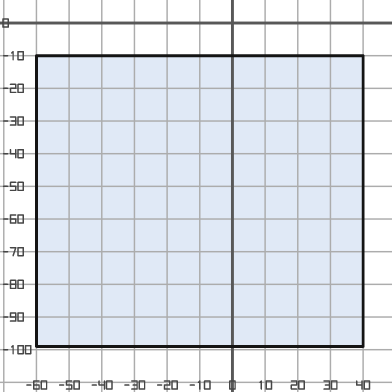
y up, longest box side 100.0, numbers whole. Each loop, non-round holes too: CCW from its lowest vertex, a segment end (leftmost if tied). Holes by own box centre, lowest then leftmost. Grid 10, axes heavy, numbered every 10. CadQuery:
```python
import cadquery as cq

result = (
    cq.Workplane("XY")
    .moveTo(-60.0, -99.0)
    .lineTo(40.0, -99.0)
    .lineTo(40.0, -10.0)
    .lineTo(-60.0, -10.0)
    .close()
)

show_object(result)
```